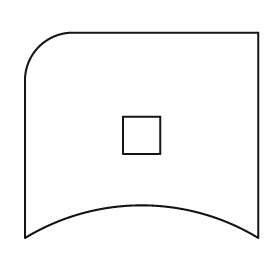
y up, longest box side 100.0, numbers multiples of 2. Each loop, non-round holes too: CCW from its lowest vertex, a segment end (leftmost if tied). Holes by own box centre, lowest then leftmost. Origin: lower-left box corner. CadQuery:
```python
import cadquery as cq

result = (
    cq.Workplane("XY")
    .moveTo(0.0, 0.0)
    .threePointArc((50.0, 14.0), (100.0, 0.0))
    .lineTo(100.0, 88.0)
    .lineTo(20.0, 88.0)
    .threePointArc((6.0, 82.0), (0.0, 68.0))
    .close()
    .moveTo(42.0, 36.0)
    .lineTo(58.0, 36.0)
    .lineTo(58.0, 52.0)
    .lineTo(42.0, 52.0)
    .close()
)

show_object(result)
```